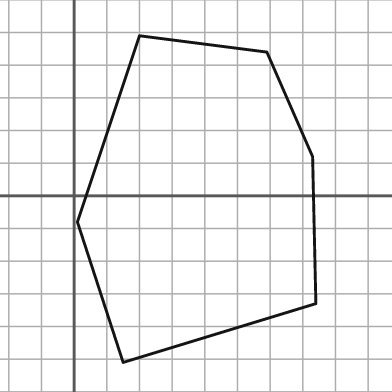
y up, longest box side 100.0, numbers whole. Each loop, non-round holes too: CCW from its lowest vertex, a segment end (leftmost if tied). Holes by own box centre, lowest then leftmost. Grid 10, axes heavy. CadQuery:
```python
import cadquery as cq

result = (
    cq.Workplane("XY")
    .moveTo(15.0, -51.0)
    .lineTo(74.0, -33.0)
    .lineTo(73.0, 12.0)
    .lineTo(59.0, 44.0)
    .lineTo(20.0, 49.0)
    .lineTo(1.0, -8.0)
    .close()
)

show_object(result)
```